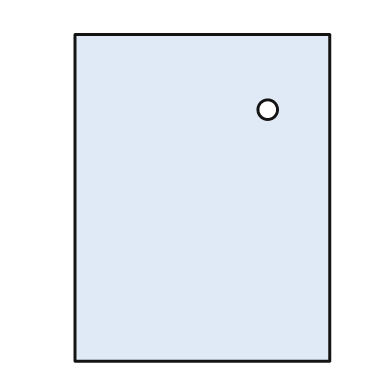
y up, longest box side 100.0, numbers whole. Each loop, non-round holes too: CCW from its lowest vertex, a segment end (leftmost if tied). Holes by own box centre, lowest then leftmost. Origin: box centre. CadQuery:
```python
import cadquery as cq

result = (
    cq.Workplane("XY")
    .moveTo(-39.0, -50.0)
    .lineTo(39.0, -50.0)
    .lineTo(39.0, 50.0)
    .lineTo(-39.0, 50.0)
    .close()
    .moveTo(20.0, 27.0)
    .circle(3.0)
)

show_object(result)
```